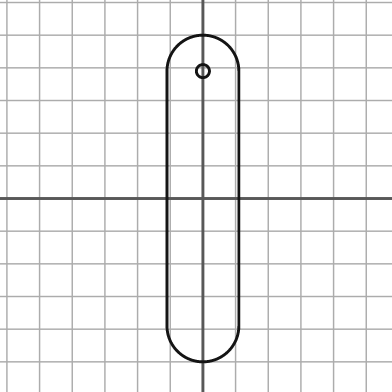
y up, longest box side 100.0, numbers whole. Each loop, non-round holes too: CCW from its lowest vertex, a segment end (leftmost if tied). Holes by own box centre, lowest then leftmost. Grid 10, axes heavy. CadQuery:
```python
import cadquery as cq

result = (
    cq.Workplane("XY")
    .moveTo(-11.0, -39.0)
    .threePointArc((0.0, -50.0), (11.0, -39.0))
    .lineTo(11.0, 39.0)
    .threePointArc((0.0, 50.0), (-11.0, 39.0))
    .close()
    .moveTo(0.0, 39.0)
    .circle(2.0)
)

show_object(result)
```